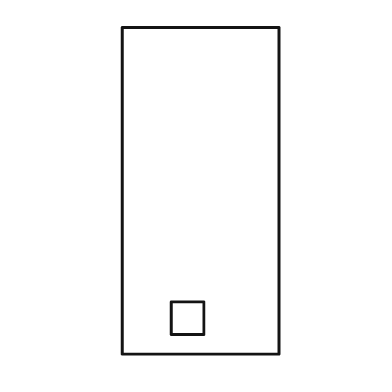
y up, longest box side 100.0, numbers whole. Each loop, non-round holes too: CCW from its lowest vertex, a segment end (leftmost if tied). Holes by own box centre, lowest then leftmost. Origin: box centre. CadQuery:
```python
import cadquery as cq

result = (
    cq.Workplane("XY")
    .moveTo(-24.0, -50.0)
    .lineTo(24.0, -50.0)
    .lineTo(24.0, 50.0)
    .lineTo(-24.0, 50.0)
    .close()
    .moveTo(-9.0, -44.0)
    .lineTo(1.0, -44.0)
    .lineTo(1.0, -34.0)
    .lineTo(-9.0, -34.0)
    .close()
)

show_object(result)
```